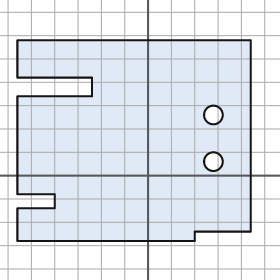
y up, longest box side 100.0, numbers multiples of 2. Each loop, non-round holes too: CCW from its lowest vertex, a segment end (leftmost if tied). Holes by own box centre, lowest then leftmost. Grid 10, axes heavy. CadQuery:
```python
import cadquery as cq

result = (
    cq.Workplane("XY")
    .moveTo(-56.0, -28.0)
    .lineTo(20.0, -28.0)
    .lineTo(20.0, -24.0)
    .lineTo(44.0, -24.0)
    .lineTo(44.0, 58.0)
    .lineTo(-56.0, 58.0)
    .lineTo(-56.0, 42.0)
    .lineTo(-24.0, 42.0)
    .lineTo(-24.0, 34.0)
    .lineTo(-56.0, 34.0)
    .lineTo(-56.0, -8.0)
    .lineTo(-40.0, -8.0)
    .lineTo(-40.0, -14.0)
    .lineTo(-56.0, -14.0)
    .close()
    .moveTo(28.0, 6.0)
    .circle(4.0)
    .moveTo(28.0, 26.0)
    .circle(4.0)
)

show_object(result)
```